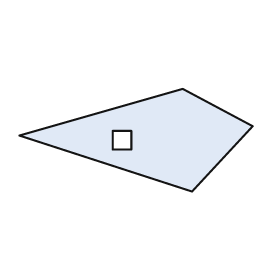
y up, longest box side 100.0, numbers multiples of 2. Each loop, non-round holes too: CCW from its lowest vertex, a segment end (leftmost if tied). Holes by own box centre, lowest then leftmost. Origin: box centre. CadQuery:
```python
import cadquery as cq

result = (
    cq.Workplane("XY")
    .moveTo(24.0, -22.0)
    .lineTo(50.0, 6.0)
    .lineTo(20.0, 22.0)
    .lineTo(-50.0, 2.0)
    .close()
    .moveTo(-10.0, -4.0)
    .lineTo(-2.0, -4.0)
    .lineTo(-2.0, 4.0)
    .lineTo(-10.0, 4.0)
    .close()
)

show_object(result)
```